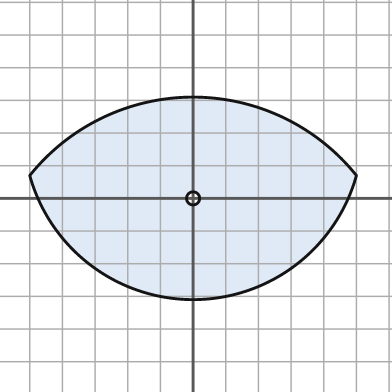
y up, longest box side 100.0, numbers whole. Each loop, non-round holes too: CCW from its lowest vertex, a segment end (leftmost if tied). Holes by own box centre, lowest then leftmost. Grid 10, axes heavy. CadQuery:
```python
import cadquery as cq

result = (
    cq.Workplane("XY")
    .moveTo(-50.0, 7.0)
    .threePointArc((0.0, -31.0), (50.0, 7.0))
    .threePointArc((0.0, 31.0), (-50.0, 7.0))
    .close()
    .moveTo(0.0, 0.0)
    .circle(2.0)
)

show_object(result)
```